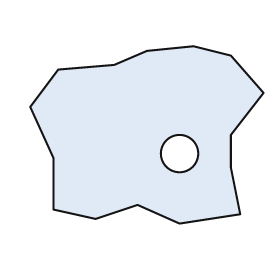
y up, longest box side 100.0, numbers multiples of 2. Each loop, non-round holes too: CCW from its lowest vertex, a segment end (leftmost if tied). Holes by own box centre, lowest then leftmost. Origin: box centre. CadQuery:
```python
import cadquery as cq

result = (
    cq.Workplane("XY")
    .moveTo(14.0, -38.0)
    .lineTo(40.0, -34.0)
    .lineTo(36.0, -14.0)
    .lineTo(36.0, 0.0)
    .lineTo(50.0, 18.0)
    .lineTo(36.0, 34.0)
    .lineTo(20.0, 38.0)
    .lineTo(0.0, 36.0)
    .lineTo(-14.0, 30.0)
    .lineTo(-38.0, 28.0)
    .lineTo(-50.0, 12.0)
    .lineTo(-40.0, -10.0)
    .lineTo(-40.0, -32.0)
    .lineTo(-22.0, -36.0)
    .lineTo(-4.0, -30.0)
    .close()
    .moveTo(14.0, -8.0)
    .circle(8.0)
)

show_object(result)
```